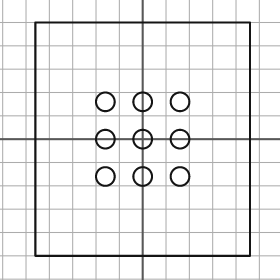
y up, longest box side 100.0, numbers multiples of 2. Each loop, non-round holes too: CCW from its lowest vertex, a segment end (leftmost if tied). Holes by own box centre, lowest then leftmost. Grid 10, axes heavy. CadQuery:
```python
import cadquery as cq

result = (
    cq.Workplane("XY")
    .moveTo(-46.0, -50.0)
    .lineTo(46.0, -50.0)
    .lineTo(46.0, 50.0)
    .lineTo(-46.0, 50.0)
    .close()
    .moveTo(-16.0, -16.0)
    .circle(4.0)
    .moveTo(0.0, -16.0)
    .circle(4.0)
    .moveTo(16.0, -16.0)
    .circle(4.0)
    .moveTo(-16.0, 0.0)
    .circle(4.0)
    .moveTo(0.0, 0.0)
    .circle(4.0)
    .moveTo(16.0, 0.0)
    .circle(4.0)
    .moveTo(-16.0, 16.0)
    .circle(4.0)
    .moveTo(0.0, 16.0)
    .circle(4.0)
    .moveTo(16.0, 16.0)
    .circle(4.0)
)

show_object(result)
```